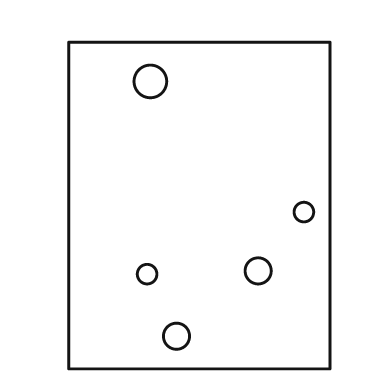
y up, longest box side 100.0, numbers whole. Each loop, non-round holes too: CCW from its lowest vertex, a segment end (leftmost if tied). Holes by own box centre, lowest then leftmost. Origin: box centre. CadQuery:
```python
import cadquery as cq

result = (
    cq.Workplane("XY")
    .moveTo(-40.0, -50.0)
    .lineTo(40.0, -50.0)
    .lineTo(40.0, 50.0)
    .lineTo(-40.0, 50.0)
    .close()
    .moveTo(-7.0, -40.0)
    .circle(4.0)
    .moveTo(-16.0, -21.0)
    .circle(3.0)
    .moveTo(18.0, -20.0)
    .circle(4.0)
    .moveTo(32.0, -2.0)
    .circle(3.0)
    .moveTo(-15.0, 38.0)
    .circle(5.0)
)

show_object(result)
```